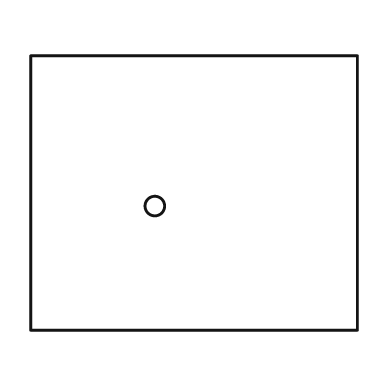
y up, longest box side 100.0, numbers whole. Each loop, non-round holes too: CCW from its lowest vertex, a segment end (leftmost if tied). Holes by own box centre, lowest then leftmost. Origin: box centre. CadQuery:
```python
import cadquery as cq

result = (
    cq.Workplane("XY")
    .moveTo(-50.0, -42.0)
    .lineTo(50.0, -42.0)
    .lineTo(50.0, 42.0)
    .lineTo(-50.0, 42.0)
    .close()
    .moveTo(-12.0, -4.0)
    .circle(3.0)
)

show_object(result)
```